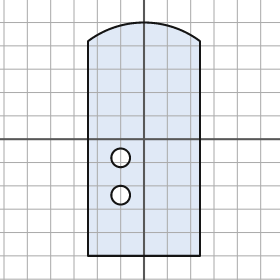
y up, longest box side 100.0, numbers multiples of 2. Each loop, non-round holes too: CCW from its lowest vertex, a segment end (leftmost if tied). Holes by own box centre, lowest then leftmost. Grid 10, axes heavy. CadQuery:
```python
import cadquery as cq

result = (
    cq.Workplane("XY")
    .moveTo(-24.0, -50.0)
    .lineTo(24.0, -50.0)
    .lineTo(24.0, 42.0)
    .threePointArc((0.0, 50.0), (-24.0, 42.0))
    .close()
    .moveTo(-10.0, -24.0)
    .circle(4.0)
    .moveTo(-10.0, -8.0)
    .circle(4.0)
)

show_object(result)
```